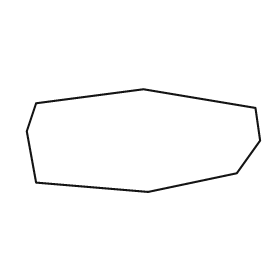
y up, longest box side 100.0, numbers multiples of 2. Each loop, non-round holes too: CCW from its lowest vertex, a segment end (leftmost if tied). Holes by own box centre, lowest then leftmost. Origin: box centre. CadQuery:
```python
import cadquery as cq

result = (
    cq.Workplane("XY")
    .moveTo(2.0, -22.0)
    .lineTo(40.0, -14.0)
    .lineTo(50.0, 0.0)
    .lineTo(48.0, 14.0)
    .lineTo(0.0, 22.0)
    .lineTo(-46.0, 16.0)
    .lineTo(-50.0, 4.0)
    .lineTo(-46.0, -18.0)
    .close()
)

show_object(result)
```